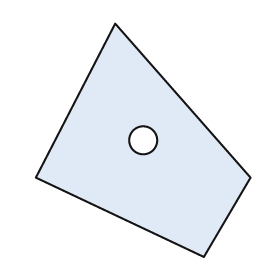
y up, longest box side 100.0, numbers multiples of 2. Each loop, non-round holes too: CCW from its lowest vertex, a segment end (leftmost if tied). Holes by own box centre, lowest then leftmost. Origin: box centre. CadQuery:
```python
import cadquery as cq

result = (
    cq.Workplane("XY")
    .moveTo(26.0, -50.0)
    .lineTo(46.0, -16.0)
    .lineTo(-12.0, 50.0)
    .lineTo(-46.0, -16.0)
    .close()
    .moveTo(0.0, 0.0)
    .circle(6.0)
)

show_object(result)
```